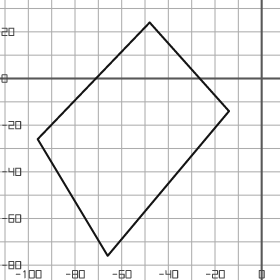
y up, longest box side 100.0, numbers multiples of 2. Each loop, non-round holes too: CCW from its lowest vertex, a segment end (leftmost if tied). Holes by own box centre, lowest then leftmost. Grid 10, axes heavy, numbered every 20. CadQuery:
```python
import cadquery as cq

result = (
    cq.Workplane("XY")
    .moveTo(-66.0, -76.0)
    .lineTo(-14.0, -14.0)
    .lineTo(-48.0, 24.0)
    .lineTo(-96.0, -26.0)
    .close()
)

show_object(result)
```